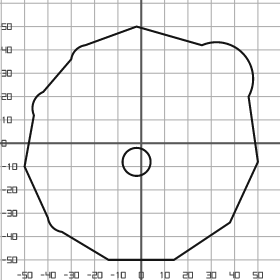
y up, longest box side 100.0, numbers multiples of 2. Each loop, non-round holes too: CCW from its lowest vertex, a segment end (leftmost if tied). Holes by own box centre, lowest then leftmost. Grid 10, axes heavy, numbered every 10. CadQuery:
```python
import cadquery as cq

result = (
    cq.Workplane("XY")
    .moveTo(-14.0, -50.0)
    .lineTo(14.0, -50.0)
    .lineTo(38.0, -34.0)
    .lineTo(50.0, -8.0)
    .lineTo(46.0, 20.0)
    .threePointArc((44.0, 38.0), (26.0, 42.0))
    .lineTo(-2.0, 50.0)
    .lineTo(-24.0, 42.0)
    .threePointArc((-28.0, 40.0), (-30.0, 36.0))
    .lineTo(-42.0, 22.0)
    .threePointArc((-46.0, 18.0), (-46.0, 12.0))
    .lineTo(-50.0, -10.0)
    .lineTo(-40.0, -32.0)
    .threePointArc((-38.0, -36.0), (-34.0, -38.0))
    .close()
    .moveTo(-2.0, -8.0)
    .circle(6.0)
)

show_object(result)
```